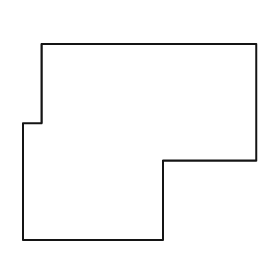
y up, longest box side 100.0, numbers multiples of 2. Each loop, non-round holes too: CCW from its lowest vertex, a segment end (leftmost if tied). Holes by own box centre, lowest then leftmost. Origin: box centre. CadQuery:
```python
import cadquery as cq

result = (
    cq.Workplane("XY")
    .moveTo(-50.0, -42.0)
    .lineTo(10.0, -42.0)
    .lineTo(10.0, -8.0)
    .lineTo(50.0, -8.0)
    .lineTo(50.0, 42.0)
    .lineTo(-42.0, 42.0)
    .lineTo(-42.0, 8.0)
    .lineTo(-50.0, 8.0)
    .close()
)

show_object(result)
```